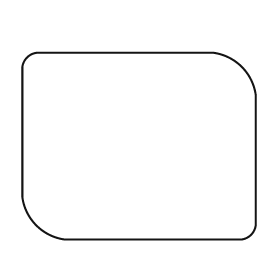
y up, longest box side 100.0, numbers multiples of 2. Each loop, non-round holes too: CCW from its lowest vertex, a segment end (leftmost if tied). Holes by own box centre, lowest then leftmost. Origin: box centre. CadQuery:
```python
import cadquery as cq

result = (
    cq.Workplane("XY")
    .moveTo(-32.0, -40.0)
    .lineTo(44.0, -40.0)
    .threePointArc((48.0, -38.0), (50.0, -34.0))
    .lineTo(50.0, 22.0)
    .threePointArc((44.0, 34.0), (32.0, 40.0))
    .lineTo(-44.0, 40.0)
    .threePointArc((-48.0, 38.0), (-50.0, 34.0))
    .lineTo(-50.0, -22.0)
    .threePointArc((-44.0, -34.0), (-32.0, -40.0))
    .close()
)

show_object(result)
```